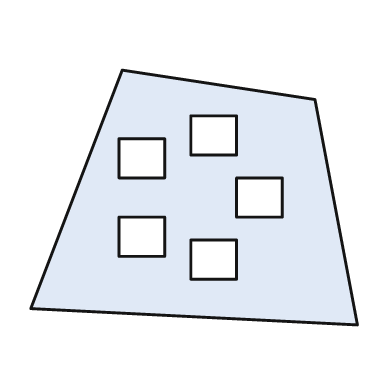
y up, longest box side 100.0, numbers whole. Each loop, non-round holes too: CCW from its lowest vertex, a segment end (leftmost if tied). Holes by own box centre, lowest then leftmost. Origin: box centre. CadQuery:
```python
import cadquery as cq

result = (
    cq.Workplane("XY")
    .moveTo(50.0, -39.0)
    .lineTo(37.0, 30.0)
    .lineTo(-22.0, 39.0)
    .lineTo(-50.0, -34.0)
    .close()
    .moveTo(-1.0, -25.0)
    .lineTo(13.0, -25.0)
    .lineTo(13.0, -13.0)
    .lineTo(-1.0, -13.0)
    .close()
    .moveTo(-23.0, -18.0)
    .lineTo(-9.0, -18.0)
    .lineTo(-9.0, -6.0)
    .lineTo(-23.0, -6.0)
    .close()
    .moveTo(13.0, -6.0)
    .lineTo(27.0, -6.0)
    .lineTo(27.0, 6.0)
    .lineTo(13.0, 6.0)
    .close()
    .moveTo(-23.0, 6.0)
    .lineTo(-9.0, 6.0)
    .lineTo(-9.0, 18.0)
    .lineTo(-23.0, 18.0)
    .close()
    .moveTo(-1.0, 13.0)
    .lineTo(13.0, 13.0)
    .lineTo(13.0, 25.0)
    .lineTo(-1.0, 25.0)
    .close()
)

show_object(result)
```